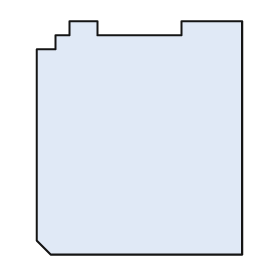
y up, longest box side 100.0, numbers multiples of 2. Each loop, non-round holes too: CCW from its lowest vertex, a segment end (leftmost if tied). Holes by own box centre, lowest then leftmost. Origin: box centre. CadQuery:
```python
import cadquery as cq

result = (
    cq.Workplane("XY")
    .moveTo(-38.0, -50.0)
    .lineTo(44.0, -50.0)
    .lineTo(44.0, 50.0)
    .lineTo(18.0, 50.0)
    .lineTo(18.0, 44.0)
    .lineTo(-18.0, 44.0)
    .lineTo(-18.0, 50.0)
    .lineTo(-30.0, 50.0)
    .lineTo(-30.0, 44.0)
    .lineTo(-36.0, 44.0)
    .lineTo(-36.0, 38.0)
    .lineTo(-44.0, 38.0)
    .lineTo(-44.0, -44.0)
    .close()
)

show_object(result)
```